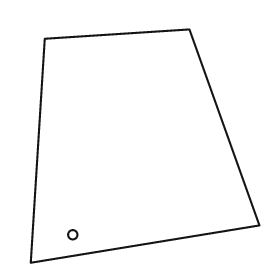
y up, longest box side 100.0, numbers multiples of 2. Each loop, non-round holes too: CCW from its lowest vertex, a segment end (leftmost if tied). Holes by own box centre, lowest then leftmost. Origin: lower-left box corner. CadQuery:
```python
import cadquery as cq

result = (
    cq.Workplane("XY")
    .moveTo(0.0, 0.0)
    .lineTo(98.0, 16.0)
    .lineTo(68.0, 100.0)
    .lineTo(6.0, 96.0)
    .close()
    .moveTo(18.0, 12.0)
    .circle(2.0)
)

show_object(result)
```